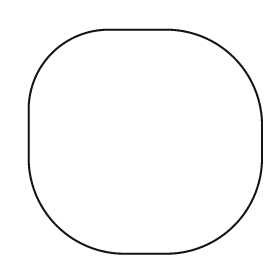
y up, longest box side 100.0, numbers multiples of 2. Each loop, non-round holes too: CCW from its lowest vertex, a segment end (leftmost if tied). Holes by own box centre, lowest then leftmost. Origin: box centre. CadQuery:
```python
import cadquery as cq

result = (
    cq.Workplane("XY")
    .moveTo(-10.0, -48.0)
    .lineTo(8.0, -48.0)
    .threePointArc((38.0, -36.0), (50.0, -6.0))
    .lineTo(50.0, 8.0)
    .threePointArc((38.0, 36.0), (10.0, 48.0))
    .lineTo(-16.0, 48.0)
    .threePointArc((-40.0, 38.0), (-50.0, 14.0))
    .lineTo(-50.0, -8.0)
    .threePointArc((-38.0, -36.0), (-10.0, -48.0))
    .close()
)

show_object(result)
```